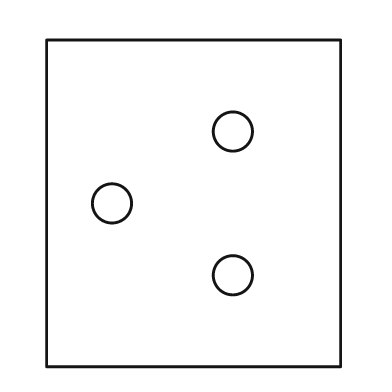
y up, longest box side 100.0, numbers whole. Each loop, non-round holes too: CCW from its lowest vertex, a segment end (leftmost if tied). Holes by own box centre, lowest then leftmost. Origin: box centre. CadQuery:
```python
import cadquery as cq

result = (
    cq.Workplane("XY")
    .moveTo(-45.0, -50.0)
    .lineTo(45.0, -50.0)
    .lineTo(45.0, 50.0)
    .lineTo(-45.0, 50.0)
    .close()
    .moveTo(12.0, -22.0)
    .circle(6.0)
    .moveTo(-25.0, 0.0)
    .circle(6.0)
    .moveTo(12.0, 22.0)
    .circle(6.0)
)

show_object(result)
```